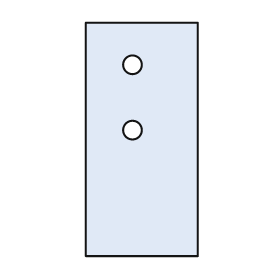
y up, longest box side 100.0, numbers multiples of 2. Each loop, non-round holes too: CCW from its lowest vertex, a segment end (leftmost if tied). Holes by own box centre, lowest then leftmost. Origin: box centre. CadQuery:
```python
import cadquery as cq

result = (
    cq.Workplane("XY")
    .moveTo(-24.0, -50.0)
    .lineTo(24.0, -50.0)
    .lineTo(24.0, 50.0)
    .lineTo(-24.0, 50.0)
    .close()
    .moveTo(-4.0, 4.0)
    .circle(4.0)
    .moveTo(-4.0, 32.0)
    .circle(4.0)
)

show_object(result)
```